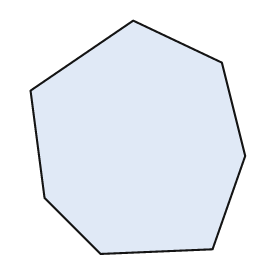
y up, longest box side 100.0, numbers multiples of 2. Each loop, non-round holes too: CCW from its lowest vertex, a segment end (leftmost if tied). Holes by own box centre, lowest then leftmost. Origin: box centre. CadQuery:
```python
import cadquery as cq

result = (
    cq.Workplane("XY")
    .moveTo(-16.0, -50.0)
    .lineTo(32.0, -48.0)
    .lineTo(46.0, -8.0)
    .lineTo(36.0, 32.0)
    .lineTo(-2.0, 50.0)
    .lineTo(-46.0, 20.0)
    .lineTo(-40.0, -26.0)
    .close()
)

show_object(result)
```